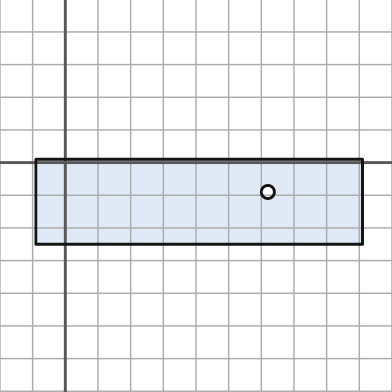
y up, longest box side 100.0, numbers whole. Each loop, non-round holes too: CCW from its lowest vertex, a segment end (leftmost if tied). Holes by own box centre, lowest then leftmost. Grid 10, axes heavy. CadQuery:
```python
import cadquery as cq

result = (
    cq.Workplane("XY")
    .moveTo(-9.0, -25.0)
    .lineTo(91.0, -25.0)
    .lineTo(91.0, 1.0)
    .lineTo(-9.0, 1.0)
    .close()
    .moveTo(62.0, -9.0)
    .circle(2.0)
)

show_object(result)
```